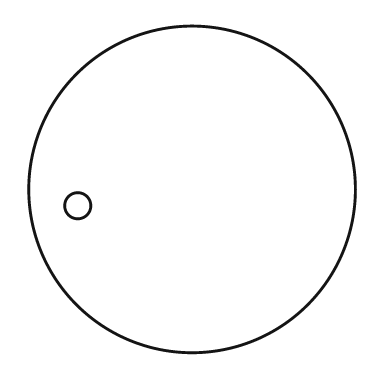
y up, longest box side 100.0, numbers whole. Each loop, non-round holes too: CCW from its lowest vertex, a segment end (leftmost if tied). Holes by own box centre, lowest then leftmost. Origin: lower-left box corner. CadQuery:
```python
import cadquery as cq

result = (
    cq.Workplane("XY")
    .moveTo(50.0, 50.0)
    .circle(50.0)
    .moveTo(15.0, 45.0)
    .circle(4.0)
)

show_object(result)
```